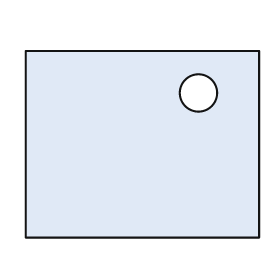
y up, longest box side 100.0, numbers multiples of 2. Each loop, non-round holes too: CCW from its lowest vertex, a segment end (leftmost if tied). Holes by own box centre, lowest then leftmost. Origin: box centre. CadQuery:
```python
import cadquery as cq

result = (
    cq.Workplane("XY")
    .moveTo(-50.0, -40.0)
    .lineTo(50.0, -40.0)
    .lineTo(50.0, 40.0)
    .lineTo(-50.0, 40.0)
    .close()
    .moveTo(24.0, 22.0)
    .circle(8.0)
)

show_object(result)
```